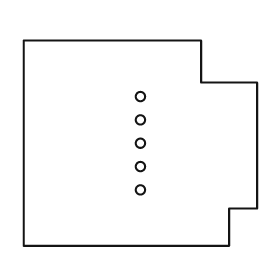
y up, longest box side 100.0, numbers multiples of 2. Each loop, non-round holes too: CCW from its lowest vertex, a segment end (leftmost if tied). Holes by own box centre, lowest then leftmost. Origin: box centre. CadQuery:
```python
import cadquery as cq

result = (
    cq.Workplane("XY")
    .moveTo(-50.0, -44.0)
    .lineTo(38.0, -44.0)
    .lineTo(38.0, -28.0)
    .lineTo(50.0, -28.0)
    .lineTo(50.0, 26.0)
    .lineTo(26.0, 26.0)
    .lineTo(26.0, 44.0)
    .lineTo(-50.0, 44.0)
    .close()
    .moveTo(0.0, -20.0)
    .circle(2.0)
    .moveTo(0.0, -10.0)
    .circle(2.0)
    .moveTo(0.0, 0.0)
    .circle(2.0)
    .moveTo(0.0, 10.0)
    .circle(2.0)
    .moveTo(0.0, 20.0)
    .circle(2.0)
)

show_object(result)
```